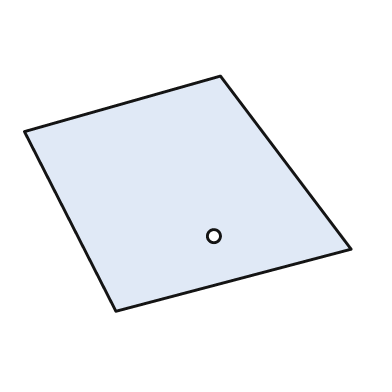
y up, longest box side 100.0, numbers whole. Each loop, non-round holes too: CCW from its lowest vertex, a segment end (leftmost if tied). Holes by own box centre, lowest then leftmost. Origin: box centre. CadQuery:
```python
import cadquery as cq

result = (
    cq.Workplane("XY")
    .moveTo(-22.0, -36.0)
    .lineTo(50.0, -17.0)
    .lineTo(10.0, 36.0)
    .lineTo(-50.0, 19.0)
    .close()
    .moveTo(8.0, -13.0)
    .circle(2.0)
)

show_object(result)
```